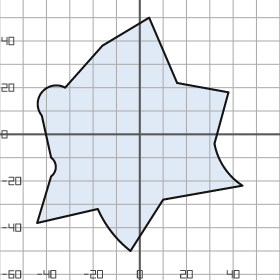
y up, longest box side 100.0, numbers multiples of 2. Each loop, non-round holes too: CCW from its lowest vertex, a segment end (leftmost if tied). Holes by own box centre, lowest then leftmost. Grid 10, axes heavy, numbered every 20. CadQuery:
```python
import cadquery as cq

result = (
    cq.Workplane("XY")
    .moveTo(-4.0, -50.0)
    .lineTo(10.0, -28.0)
    .lineTo(44.0, -22.0)
    .threePointArc((36.0, -14.0), (32.0, -4.0))
    .lineTo(38.0, 18.0)
    .lineTo(16.0, 22.0)
    .lineTo(4.0, 50.0)
    .lineTo(-16.0, 38.0)
    .lineTo(-32.0, 20.0)
    .threePointArc((-42.0, 18.0), (-42.0, 8.0))
    .lineTo(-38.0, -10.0)
    .threePointArc((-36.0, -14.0), (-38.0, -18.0))
    .lineTo(-44.0, -38.0)
    .lineTo(-18.0, -32.0)
    .threePointArc((-12.0, -42.0), (-4.0, -50.0))
    .close()
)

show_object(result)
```